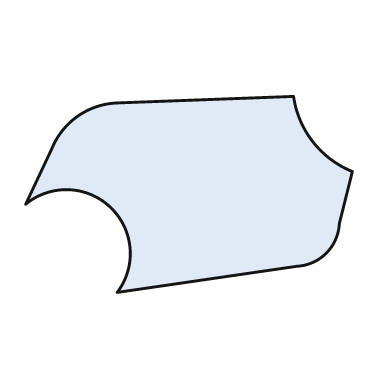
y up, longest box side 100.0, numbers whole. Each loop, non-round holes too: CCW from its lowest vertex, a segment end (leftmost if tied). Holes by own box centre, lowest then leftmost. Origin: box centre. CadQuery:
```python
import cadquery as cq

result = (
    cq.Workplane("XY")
    .moveTo(-22.0, -30.0)
    .lineTo(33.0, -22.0)
    .threePointArc((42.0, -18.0), (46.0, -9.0))
    .lineTo(50.0, 7.0)
    .threePointArc((38.0, 16.0), (32.0, 30.0))
    .lineTo(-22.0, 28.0)
    .threePointArc((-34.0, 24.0), (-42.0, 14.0))
    .lineTo(-50.0, -3.0)
    .threePointArc((-24.0, -4.0), (-22.0, -30.0))
    .close()
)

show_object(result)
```